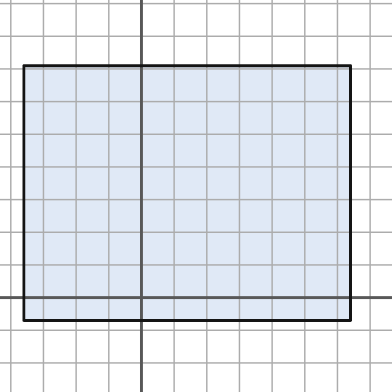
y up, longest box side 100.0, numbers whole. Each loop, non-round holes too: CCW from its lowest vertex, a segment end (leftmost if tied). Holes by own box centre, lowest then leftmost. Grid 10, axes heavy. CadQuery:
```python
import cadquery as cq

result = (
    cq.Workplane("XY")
    .moveTo(-36.0, -7.0)
    .lineTo(64.0, -7.0)
    .lineTo(64.0, 71.0)
    .lineTo(-36.0, 71.0)
    .close()
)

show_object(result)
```